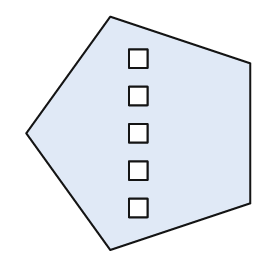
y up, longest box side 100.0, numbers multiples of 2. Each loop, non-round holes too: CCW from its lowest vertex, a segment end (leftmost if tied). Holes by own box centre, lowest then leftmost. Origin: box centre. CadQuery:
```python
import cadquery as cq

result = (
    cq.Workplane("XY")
    .moveTo(-12.0, -50.0)
    .lineTo(48.0, -30.0)
    .lineTo(48.0, 30.0)
    .lineTo(-12.0, 50.0)
    .lineTo(-48.0, 0.0)
    .close()
    .moveTo(-4.0, -36.0)
    .lineTo(4.0, -36.0)
    .lineTo(4.0, -28.0)
    .lineTo(-4.0, -28.0)
    .close()
    .moveTo(-4.0, -20.0)
    .lineTo(4.0, -20.0)
    .lineTo(4.0, -12.0)
    .lineTo(-4.0, -12.0)
    .close()
    .moveTo(-4.0, -4.0)
    .lineTo(4.0, -4.0)
    .lineTo(4.0, 4.0)
    .lineTo(-4.0, 4.0)
    .close()
    .moveTo(-4.0, 12.0)
    .lineTo(4.0, 12.0)
    .lineTo(4.0, 20.0)
    .lineTo(-4.0, 20.0)
    .close()
    .moveTo(-4.0, 28.0)
    .lineTo(4.0, 28.0)
    .lineTo(4.0, 36.0)
    .lineTo(-4.0, 36.0)
    .close()
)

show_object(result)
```